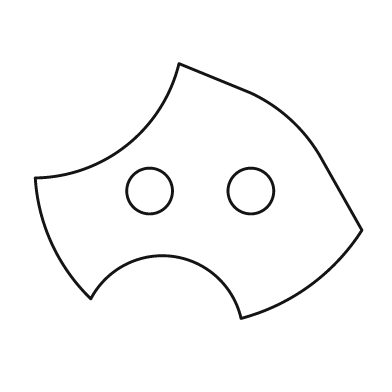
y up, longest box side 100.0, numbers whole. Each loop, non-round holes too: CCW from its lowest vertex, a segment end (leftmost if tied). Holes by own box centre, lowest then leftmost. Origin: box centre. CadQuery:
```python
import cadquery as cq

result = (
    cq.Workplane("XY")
    .moveTo(13.0, -39.0)
    .threePointArc((34.0, -29.0), (50.0, -12.0))
    .lineTo(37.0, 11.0)
    .threePointArc((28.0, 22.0), (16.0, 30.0))
    .lineTo(-6.0, 39.0)
    .threePointArc((-22.0, 14.0), (-50.0, 4.0))
    .threePointArc((-45.0, -16.0), (-33.0, -33.0))
    .threePointArc((-8.0, -20.0), (13.0, -39.0))
    .close()
    .moveTo(-15.0, 0.0)
    .circle(7.0)
    .moveTo(16.0, 0.0)
    .circle(7.0)
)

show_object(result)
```